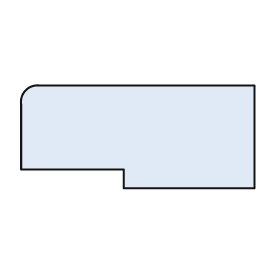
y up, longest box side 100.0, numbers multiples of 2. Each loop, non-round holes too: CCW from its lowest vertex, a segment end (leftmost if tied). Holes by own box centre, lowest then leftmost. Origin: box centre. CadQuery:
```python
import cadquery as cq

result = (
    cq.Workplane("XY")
    .moveTo(-6.0, -22.0)
    .lineTo(50.0, -22.0)
    .lineTo(50.0, 22.0)
    .lineTo(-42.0, 22.0)
    .threePointArc((-48.0, 20.0), (-50.0, 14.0))
    .lineTo(-50.0, -14.0)
    .lineTo(-6.0, -14.0)
    .close()
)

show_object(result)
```